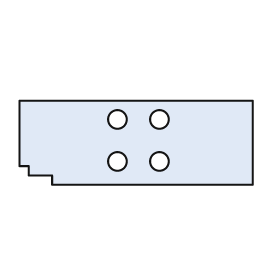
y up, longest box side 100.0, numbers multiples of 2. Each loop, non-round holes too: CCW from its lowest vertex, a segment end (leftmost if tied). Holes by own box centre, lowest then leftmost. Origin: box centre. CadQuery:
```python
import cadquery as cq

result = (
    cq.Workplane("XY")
    .moveTo(-36.0, -18.0)
    .lineTo(50.0, -18.0)
    .lineTo(50.0, 18.0)
    .lineTo(-50.0, 18.0)
    .lineTo(-50.0, -10.0)
    .lineTo(-46.0, -10.0)
    .lineTo(-46.0, -14.0)
    .lineTo(-36.0, -14.0)
    .close()
    .moveTo(-8.0, -8.0)
    .circle(4.0)
    .moveTo(10.0, -8.0)
    .circle(4.0)
    .moveTo(-8.0, 10.0)
    .circle(4.0)
    .moveTo(10.0, 10.0)
    .circle(4.0)
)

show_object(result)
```